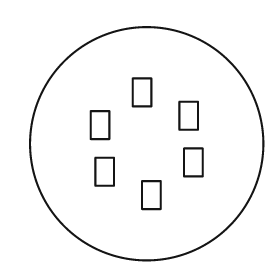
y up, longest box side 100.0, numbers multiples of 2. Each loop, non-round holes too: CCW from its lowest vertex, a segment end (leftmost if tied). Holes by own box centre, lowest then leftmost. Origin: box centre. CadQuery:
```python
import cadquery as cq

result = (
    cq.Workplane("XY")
    .moveTo(0.0, 0.0)
    .circle(50.0)
    .moveTo(-2.0, -28.0)
    .lineTo(6.0, -28.0)
    .lineTo(6.0, -16.0)
    .lineTo(-2.0, -16.0)
    .close()
    .moveTo(-22.0, -18.0)
    .lineTo(-14.0, -18.0)
    .lineTo(-14.0, -6.0)
    .lineTo(-22.0, -6.0)
    .close()
    .moveTo(16.0, -14.0)
    .lineTo(24.0, -14.0)
    .lineTo(24.0, -2.0)
    .lineTo(16.0, -2.0)
    .close()
    .moveTo(-24.0, 2.0)
    .lineTo(-16.0, 2.0)
    .lineTo(-16.0, 14.0)
    .lineTo(-24.0, 14.0)
    .close()
    .moveTo(14.0, 6.0)
    .lineTo(22.0, 6.0)
    .lineTo(22.0, 18.0)
    .lineTo(14.0, 18.0)
    .close()
    .moveTo(-6.0, 16.0)
    .lineTo(2.0, 16.0)
    .lineTo(2.0, 28.0)
    .lineTo(-6.0, 28.0)
    .close()
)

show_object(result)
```